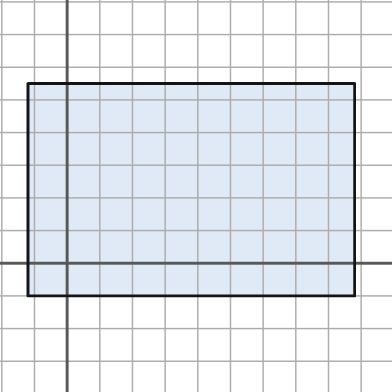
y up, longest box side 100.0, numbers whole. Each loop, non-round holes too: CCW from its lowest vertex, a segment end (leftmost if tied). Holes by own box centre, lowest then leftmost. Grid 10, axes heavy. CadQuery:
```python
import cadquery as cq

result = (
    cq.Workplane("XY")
    .moveTo(-12.0, -10.0)
    .lineTo(88.0, -10.0)
    .lineTo(88.0, 55.0)
    .lineTo(-12.0, 55.0)
    .close()
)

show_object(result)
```